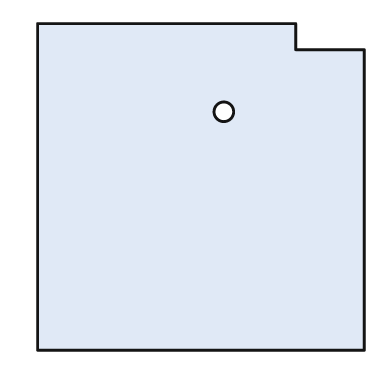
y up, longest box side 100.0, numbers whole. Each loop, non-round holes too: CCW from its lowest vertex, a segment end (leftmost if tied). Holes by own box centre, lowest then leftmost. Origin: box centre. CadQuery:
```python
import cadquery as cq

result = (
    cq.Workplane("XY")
    .moveTo(-50.0, -50.0)
    .lineTo(50.0, -50.0)
    .lineTo(50.0, 42.0)
    .lineTo(29.0, 42.0)
    .lineTo(29.0, 50.0)
    .lineTo(-50.0, 50.0)
    .close()
    .moveTo(7.0, 23.0)
    .circle(3.0)
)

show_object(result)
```